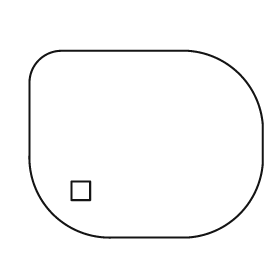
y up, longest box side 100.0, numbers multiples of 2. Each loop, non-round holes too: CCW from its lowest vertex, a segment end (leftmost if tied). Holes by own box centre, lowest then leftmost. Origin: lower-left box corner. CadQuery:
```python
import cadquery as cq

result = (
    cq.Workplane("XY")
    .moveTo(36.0, 0.0)
    .lineTo(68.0, 0.0)
    .threePointArc((90.0, 10.0), (100.0, 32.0))
    .lineTo(100.0, 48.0)
    .threePointArc((90.0, 70.0), (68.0, 80.0))
    .lineTo(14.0, 80.0)
    .threePointArc((4.0, 76.0), (0.0, 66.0))
    .lineTo(0.0, 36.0)
    .threePointArc((10.0, 10.0), (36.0, 0.0))
    .close()
    .moveTo(18.0, 16.0)
    .lineTo(26.0, 16.0)
    .lineTo(26.0, 24.0)
    .lineTo(18.0, 24.0)
    .close()
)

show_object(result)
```